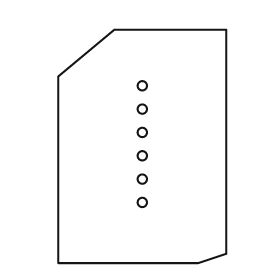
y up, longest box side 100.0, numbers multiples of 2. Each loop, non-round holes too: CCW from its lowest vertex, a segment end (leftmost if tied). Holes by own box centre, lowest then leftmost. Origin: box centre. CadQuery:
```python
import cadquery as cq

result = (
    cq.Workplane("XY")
    .moveTo(-36.0, -50.0)
    .lineTo(24.0, -50.0)
    .lineTo(36.0, -46.0)
    .lineTo(36.0, 50.0)
    .lineTo(-12.0, 50.0)
    .lineTo(-36.0, 30.0)
    .close()
    .moveTo(0.0, -24.0)
    .circle(2.0)
    .moveTo(0.0, -14.0)
    .circle(2.0)
    .moveTo(0.0, -4.0)
    .circle(2.0)
    .moveTo(0.0, 6.0)
    .circle(2.0)
    .moveTo(0.0, 16.0)
    .circle(2.0)
    .moveTo(0.0, 26.0)
    .circle(2.0)
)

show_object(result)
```